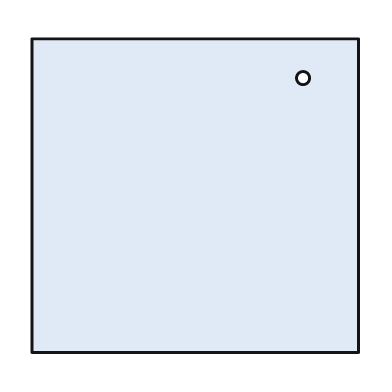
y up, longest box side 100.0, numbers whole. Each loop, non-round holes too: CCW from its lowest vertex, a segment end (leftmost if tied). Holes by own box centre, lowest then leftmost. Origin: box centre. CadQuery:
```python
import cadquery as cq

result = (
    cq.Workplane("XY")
    .moveTo(-50.0, -48.0)
    .lineTo(50.0, -48.0)
    .lineTo(50.0, 48.0)
    .lineTo(-50.0, 48.0)
    .close()
    .moveTo(33.0, 36.0)
    .circle(2.0)
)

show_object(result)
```